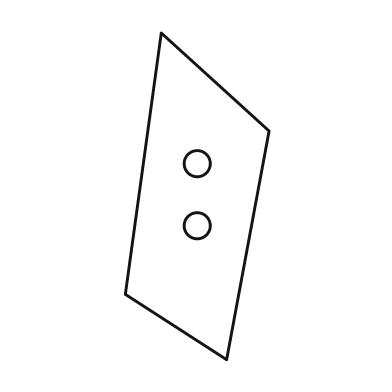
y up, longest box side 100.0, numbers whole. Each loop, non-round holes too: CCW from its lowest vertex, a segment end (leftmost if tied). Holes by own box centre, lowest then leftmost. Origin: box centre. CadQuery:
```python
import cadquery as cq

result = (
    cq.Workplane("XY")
    .moveTo(9.0, -50.0)
    .lineTo(22.0, 20.0)
    .lineTo(-11.0, 50.0)
    .lineTo(-22.0, -30.0)
    .close()
    .moveTo(0.0, -9.0)
    .circle(4.0)
    .moveTo(0.0, 10.0)
    .circle(4.0)
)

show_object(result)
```